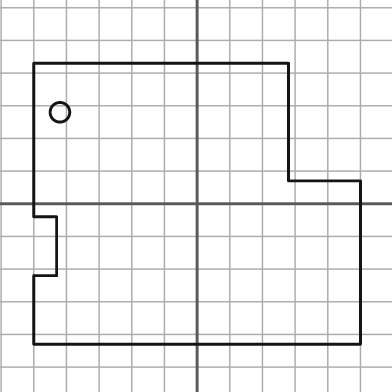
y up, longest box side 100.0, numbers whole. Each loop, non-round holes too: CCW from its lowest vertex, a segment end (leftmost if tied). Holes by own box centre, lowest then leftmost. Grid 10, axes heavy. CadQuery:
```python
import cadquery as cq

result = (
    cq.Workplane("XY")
    .moveTo(-50.0, -43.0)
    .lineTo(50.0, -43.0)
    .lineTo(50.0, 7.0)
    .lineTo(28.0, 7.0)
    .lineTo(28.0, 43.0)
    .lineTo(-50.0, 43.0)
    .lineTo(-50.0, -4.0)
    .lineTo(-43.0, -4.0)
    .lineTo(-43.0, -22.0)
    .lineTo(-50.0, -22.0)
    .close()
    .moveTo(-42.0, 28.0)
    .circle(3.0)
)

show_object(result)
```